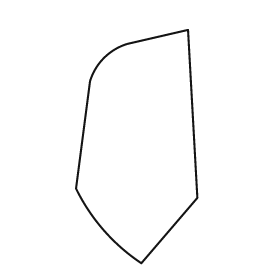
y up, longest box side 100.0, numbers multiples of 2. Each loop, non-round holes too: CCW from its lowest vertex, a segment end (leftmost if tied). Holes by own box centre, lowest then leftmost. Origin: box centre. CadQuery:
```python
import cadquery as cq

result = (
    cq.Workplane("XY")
    .moveTo(2.0, -50.0)
    .lineTo(26.0, -22.0)
    .lineTo(22.0, 50.0)
    .lineTo(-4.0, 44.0)
    .threePointArc((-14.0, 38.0), (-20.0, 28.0))
    .lineTo(-26.0, -18.0)
    .threePointArc((-14.0, -36.0), (2.0, -50.0))
    .close()
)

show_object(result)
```